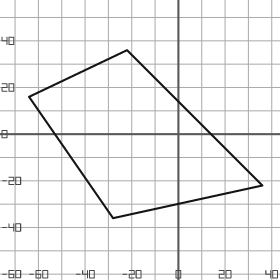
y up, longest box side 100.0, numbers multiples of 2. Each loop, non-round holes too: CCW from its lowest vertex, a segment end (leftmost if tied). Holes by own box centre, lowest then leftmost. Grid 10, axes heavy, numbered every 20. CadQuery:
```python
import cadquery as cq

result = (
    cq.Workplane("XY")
    .moveTo(-28.0, -36.0)
    .lineTo(36.0, -22.0)
    .lineTo(-22.0, 36.0)
    .lineTo(-64.0, 16.0)
    .close()
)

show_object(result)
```